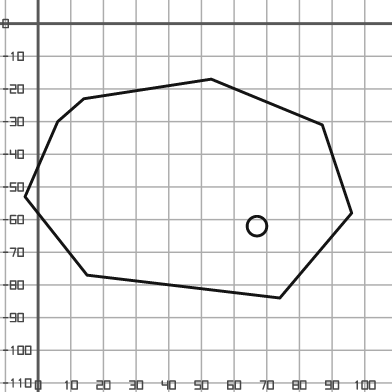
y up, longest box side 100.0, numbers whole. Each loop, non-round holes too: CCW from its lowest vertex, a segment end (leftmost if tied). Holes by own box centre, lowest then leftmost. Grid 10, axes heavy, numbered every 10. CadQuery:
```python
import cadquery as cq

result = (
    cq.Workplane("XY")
    .moveTo(74.0, -84.0)
    .lineTo(96.0, -58.0)
    .lineTo(87.0, -31.0)
    .lineTo(53.0, -17.0)
    .lineTo(14.0, -23.0)
    .lineTo(6.0, -30.0)
    .lineTo(-4.0, -53.0)
    .lineTo(15.0, -77.0)
    .close()
    .moveTo(67.0, -62.0)
    .circle(3.0)
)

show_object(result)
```